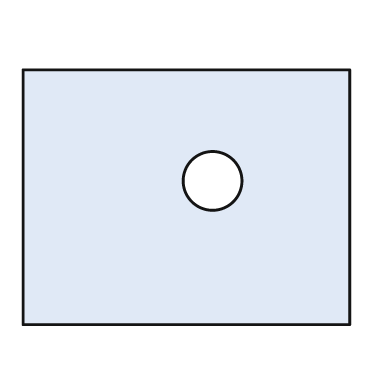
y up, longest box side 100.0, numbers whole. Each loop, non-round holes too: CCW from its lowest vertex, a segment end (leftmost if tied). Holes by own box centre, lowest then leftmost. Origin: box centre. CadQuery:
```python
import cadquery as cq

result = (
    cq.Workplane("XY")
    .moveTo(-50.0, -39.0)
    .lineTo(50.0, -39.0)
    .lineTo(50.0, 39.0)
    .lineTo(-50.0, 39.0)
    .close()
    .moveTo(8.0, 5.0)
    .circle(9.0)
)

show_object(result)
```